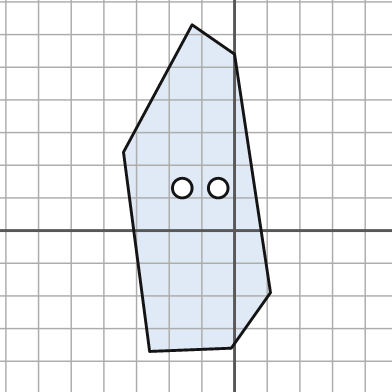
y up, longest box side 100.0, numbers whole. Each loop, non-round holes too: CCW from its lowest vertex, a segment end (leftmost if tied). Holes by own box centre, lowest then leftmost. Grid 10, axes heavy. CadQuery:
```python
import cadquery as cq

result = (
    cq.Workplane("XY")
    .moveTo(-26.0, -37.0)
    .lineTo(-1.0, -36.0)
    .lineTo(11.0, -19.0)
    .lineTo(0.0, 54.0)
    .lineTo(-13.0, 63.0)
    .lineTo(-34.0, 24.0)
    .close()
    .moveTo(-16.0, 13.0)
    .circle(3.0)
    .moveTo(-5.0, 13.0)
    .circle(3.0)
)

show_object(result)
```